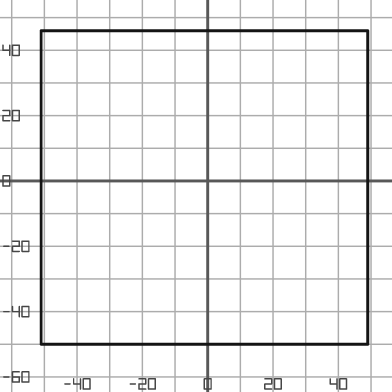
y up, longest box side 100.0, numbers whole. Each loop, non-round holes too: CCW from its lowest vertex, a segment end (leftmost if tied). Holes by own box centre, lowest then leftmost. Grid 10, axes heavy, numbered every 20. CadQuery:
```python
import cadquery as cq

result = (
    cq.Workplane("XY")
    .moveTo(-51.0, -50.0)
    .lineTo(49.0, -50.0)
    .lineTo(49.0, 46.0)
    .lineTo(-51.0, 46.0)
    .close()
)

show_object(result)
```